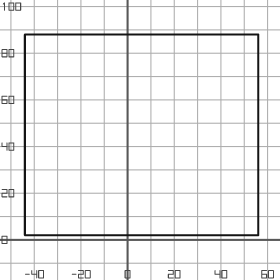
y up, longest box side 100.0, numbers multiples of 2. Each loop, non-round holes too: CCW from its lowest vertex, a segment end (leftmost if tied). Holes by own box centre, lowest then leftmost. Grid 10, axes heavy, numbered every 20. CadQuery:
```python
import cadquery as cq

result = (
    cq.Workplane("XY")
    .moveTo(-44.0, 2.0)
    .lineTo(56.0, 2.0)
    .lineTo(56.0, 88.0)
    .lineTo(-44.0, 88.0)
    .close()
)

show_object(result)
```